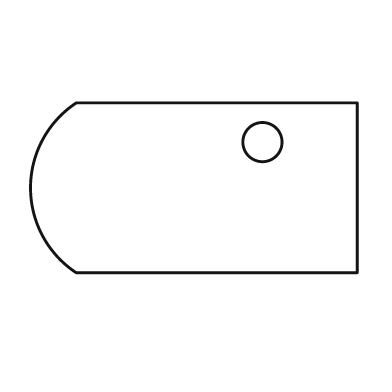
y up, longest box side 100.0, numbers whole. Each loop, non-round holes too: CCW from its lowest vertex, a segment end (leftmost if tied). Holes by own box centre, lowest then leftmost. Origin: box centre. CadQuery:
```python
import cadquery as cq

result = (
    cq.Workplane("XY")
    .moveTo(-36.0, -26.0)
    .lineTo(50.0, -26.0)
    .lineTo(50.0, 26.0)
    .lineTo(-36.0, 26.0)
    .threePointArc((-50.0, 0.0), (-36.0, -26.0))
    .close()
    .moveTo(21.0, 14.0)
    .circle(6.0)
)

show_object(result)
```